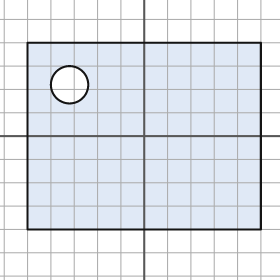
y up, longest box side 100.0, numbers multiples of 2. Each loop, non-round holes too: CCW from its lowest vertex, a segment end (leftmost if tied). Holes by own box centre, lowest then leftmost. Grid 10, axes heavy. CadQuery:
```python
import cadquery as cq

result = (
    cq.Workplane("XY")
    .moveTo(-50.0, -40.0)
    .lineTo(50.0, -40.0)
    .lineTo(50.0, 40.0)
    .lineTo(-50.0, 40.0)
    .close()
    .moveTo(-32.0, 22.0)
    .circle(8.0)
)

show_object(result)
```